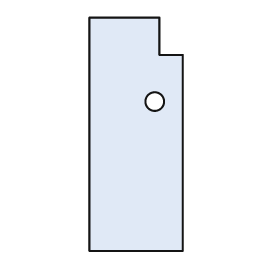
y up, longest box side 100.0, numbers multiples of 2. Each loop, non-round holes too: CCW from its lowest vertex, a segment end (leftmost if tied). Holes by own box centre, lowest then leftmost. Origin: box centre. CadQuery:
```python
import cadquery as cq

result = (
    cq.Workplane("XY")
    .moveTo(-20.0, -50.0)
    .lineTo(20.0, -50.0)
    .lineTo(20.0, 34.0)
    .lineTo(10.0, 34.0)
    .lineTo(10.0, 50.0)
    .lineTo(-20.0, 50.0)
    .close()
    .moveTo(8.0, 14.0)
    .circle(4.0)
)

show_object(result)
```